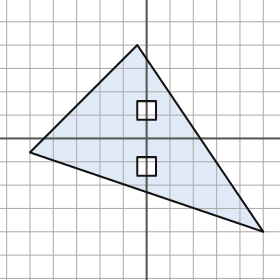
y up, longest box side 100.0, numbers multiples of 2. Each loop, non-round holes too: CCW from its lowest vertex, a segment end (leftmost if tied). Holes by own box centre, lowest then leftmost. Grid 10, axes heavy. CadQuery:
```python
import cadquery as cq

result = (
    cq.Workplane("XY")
    .moveTo(50.0, -40.0)
    .lineTo(-4.0, 40.0)
    .lineTo(-50.0, -6.0)
    .close()
    .moveTo(-4.0, -16.0)
    .lineTo(4.0, -16.0)
    .lineTo(4.0, -8.0)
    .lineTo(-4.0, -8.0)
    .close()
    .moveTo(-4.0, 8.0)
    .lineTo(4.0, 8.0)
    .lineTo(4.0, 16.0)
    .lineTo(-4.0, 16.0)
    .close()
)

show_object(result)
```